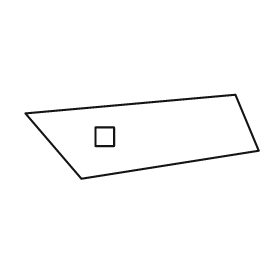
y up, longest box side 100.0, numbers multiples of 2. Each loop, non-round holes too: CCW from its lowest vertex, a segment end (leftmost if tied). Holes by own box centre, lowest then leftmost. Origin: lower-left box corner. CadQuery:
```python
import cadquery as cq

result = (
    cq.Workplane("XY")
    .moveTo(24.0, 0.0)
    .lineTo(100.0, 12.0)
    .lineTo(90.0, 36.0)
    .lineTo(0.0, 28.0)
    .close()
    .moveTo(30.0, 14.0)
    .lineTo(38.0, 14.0)
    .lineTo(38.0, 22.0)
    .lineTo(30.0, 22.0)
    .close()
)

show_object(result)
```